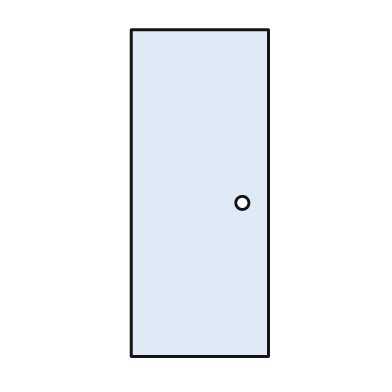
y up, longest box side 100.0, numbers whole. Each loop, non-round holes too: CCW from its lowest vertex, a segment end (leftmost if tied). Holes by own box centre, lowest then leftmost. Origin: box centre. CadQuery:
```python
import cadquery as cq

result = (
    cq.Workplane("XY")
    .moveTo(-21.0, -50.0)
    .lineTo(21.0, -50.0)
    .lineTo(21.0, 50.0)
    .lineTo(-21.0, 50.0)
    .close()
    .moveTo(13.0, -3.0)
    .circle(2.0)
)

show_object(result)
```